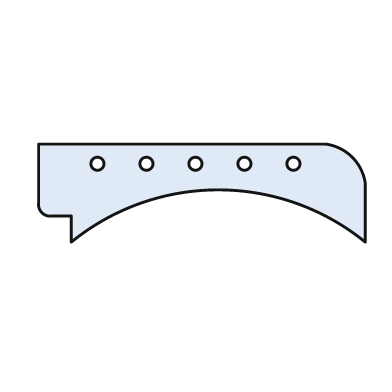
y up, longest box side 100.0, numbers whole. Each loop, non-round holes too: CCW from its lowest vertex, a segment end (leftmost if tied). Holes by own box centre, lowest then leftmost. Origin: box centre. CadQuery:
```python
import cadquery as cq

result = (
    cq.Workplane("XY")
    .moveTo(-40.0, -15.0)
    .threePointArc((5.0, 1.0), (50.0, -15.0))
    .lineTo(50.0, 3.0)
    .threePointArc((46.0, 11.0), (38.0, 15.0))
    .lineTo(-50.0, 15.0)
    .lineTo(-50.0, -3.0)
    .threePointArc((-49.0, -6.0), (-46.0, -7.0))
    .lineTo(-40.0, -7.0)
    .close()
    .moveTo(-32.0, 9.0)
    .circle(2.0)
    .moveTo(-17.0, 9.0)
    .circle(2.0)
    .moveTo(-2.0, 9.0)
    .circle(2.0)
    .moveTo(13.0, 9.0)
    .circle(2.0)
    .moveTo(28.0, 9.0)
    .circle(2.0)
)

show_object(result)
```